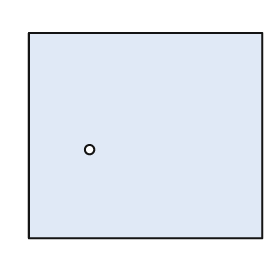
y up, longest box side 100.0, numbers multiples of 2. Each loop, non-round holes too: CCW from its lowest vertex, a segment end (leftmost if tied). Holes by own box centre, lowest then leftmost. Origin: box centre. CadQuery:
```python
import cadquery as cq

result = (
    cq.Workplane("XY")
    .moveTo(-50.0, -44.0)
    .lineTo(50.0, -44.0)
    .lineTo(50.0, 44.0)
    .lineTo(-50.0, 44.0)
    .close()
    .moveTo(-24.0, -6.0)
    .circle(2.0)
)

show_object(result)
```